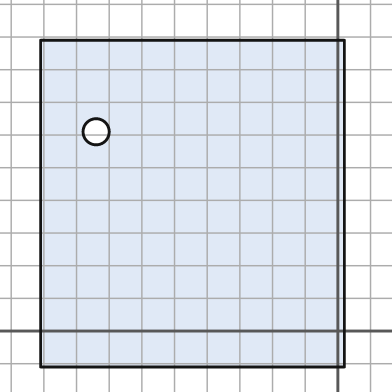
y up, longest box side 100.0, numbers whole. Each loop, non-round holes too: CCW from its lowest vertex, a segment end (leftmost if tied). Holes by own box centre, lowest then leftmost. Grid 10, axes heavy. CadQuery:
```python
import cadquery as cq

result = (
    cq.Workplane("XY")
    .moveTo(-91.0, -11.0)
    .lineTo(2.0, -11.0)
    .lineTo(2.0, 89.0)
    .lineTo(-91.0, 89.0)
    .close()
    .moveTo(-74.0, 61.0)
    .circle(4.0)
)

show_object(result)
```